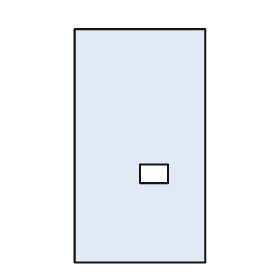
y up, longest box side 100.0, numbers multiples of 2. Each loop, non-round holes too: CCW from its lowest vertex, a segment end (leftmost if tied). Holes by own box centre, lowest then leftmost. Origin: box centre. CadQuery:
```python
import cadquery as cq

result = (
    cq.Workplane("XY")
    .moveTo(-28.0, -50.0)
    .lineTo(28.0, -50.0)
    .lineTo(28.0, 50.0)
    .lineTo(-28.0, 50.0)
    .close()
    .moveTo(0.0, -16.0)
    .lineTo(12.0, -16.0)
    .lineTo(12.0, -8.0)
    .lineTo(0.0, -8.0)
    .close()
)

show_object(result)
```